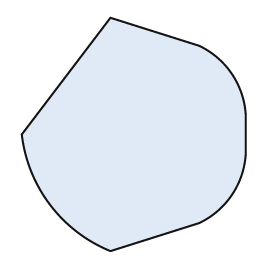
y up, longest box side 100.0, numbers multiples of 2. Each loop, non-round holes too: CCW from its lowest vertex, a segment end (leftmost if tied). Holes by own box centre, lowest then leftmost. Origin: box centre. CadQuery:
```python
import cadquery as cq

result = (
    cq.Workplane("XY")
    .moveTo(-10.0, -50.0)
    .lineTo(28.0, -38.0)
    .threePointArc((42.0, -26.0), (48.0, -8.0))
    .lineTo(48.0, 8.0)
    .threePointArc((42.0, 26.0), (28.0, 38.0))
    .lineTo(-10.0, 50.0)
    .lineTo(-48.0, 0.0)
    .threePointArc((-36.0, -30.0), (-10.0, -50.0))
    .close()
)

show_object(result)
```